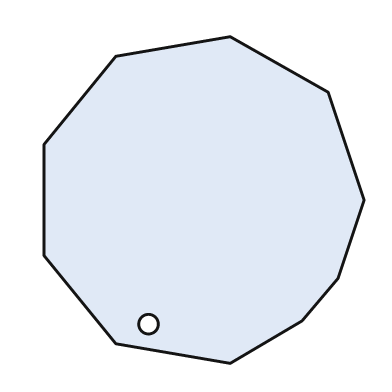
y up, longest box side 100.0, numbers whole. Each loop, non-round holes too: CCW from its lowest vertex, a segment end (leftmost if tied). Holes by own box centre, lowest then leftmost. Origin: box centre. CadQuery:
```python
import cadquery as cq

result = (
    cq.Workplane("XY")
    .moveTo(8.0, -50.0)
    .lineTo(30.0, -37.0)
    .lineTo(41.0, -24.0)
    .lineTo(49.0, 0.0)
    .lineTo(38.0, 33.0)
    .lineTo(8.0, 50.0)
    .lineTo(-27.0, 44.0)
    .lineTo(-49.0, 17.0)
    .lineTo(-49.0, -17.0)
    .lineTo(-27.0, -44.0)
    .close()
    .moveTo(-17.0, -38.0)
    .circle(3.0)
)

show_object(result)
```